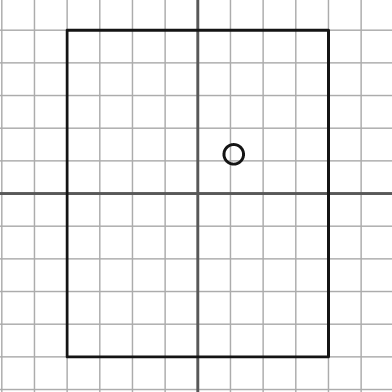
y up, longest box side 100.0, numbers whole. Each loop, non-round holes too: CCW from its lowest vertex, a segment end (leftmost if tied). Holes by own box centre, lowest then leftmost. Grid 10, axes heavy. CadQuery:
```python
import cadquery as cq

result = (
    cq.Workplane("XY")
    .moveTo(-40.0, -50.0)
    .lineTo(40.0, -50.0)
    .lineTo(40.0, 50.0)
    .lineTo(-40.0, 50.0)
    .close()
    .moveTo(11.0, 12.0)
    .circle(3.0)
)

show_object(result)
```